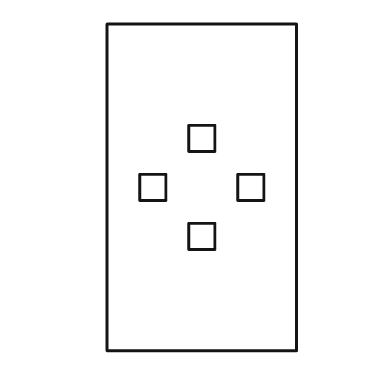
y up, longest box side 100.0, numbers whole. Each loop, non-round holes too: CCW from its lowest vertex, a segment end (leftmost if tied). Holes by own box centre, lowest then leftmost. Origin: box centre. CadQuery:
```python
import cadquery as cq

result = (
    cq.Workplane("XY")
    .moveTo(-29.0, -50.0)
    .lineTo(29.0, -50.0)
    .lineTo(29.0, 50.0)
    .lineTo(-29.0, 50.0)
    .close()
    .moveTo(-4.0, -19.0)
    .lineTo(4.0, -19.0)
    .lineTo(4.0, -11.0)
    .lineTo(-4.0, -11.0)
    .close()
    .moveTo(-19.0, -4.0)
    .lineTo(-11.0, -4.0)
    .lineTo(-11.0, 4.0)
    .lineTo(-19.0, 4.0)
    .close()
    .moveTo(11.0, -4.0)
    .lineTo(19.0, -4.0)
    .lineTo(19.0, 4.0)
    .lineTo(11.0, 4.0)
    .close()
    .moveTo(-4.0, 11.0)
    .lineTo(4.0, 11.0)
    .lineTo(4.0, 19.0)
    .lineTo(-4.0, 19.0)
    .close()
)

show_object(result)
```